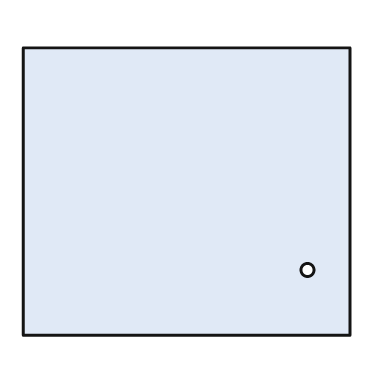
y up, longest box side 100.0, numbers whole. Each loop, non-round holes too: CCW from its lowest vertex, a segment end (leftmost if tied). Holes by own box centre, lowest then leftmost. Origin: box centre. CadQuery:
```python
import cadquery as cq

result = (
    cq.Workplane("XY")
    .moveTo(-50.0, -44.0)
    .lineTo(50.0, -44.0)
    .lineTo(50.0, 44.0)
    .lineTo(-50.0, 44.0)
    .close()
    .moveTo(37.0, -24.0)
    .circle(2.0)
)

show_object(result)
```